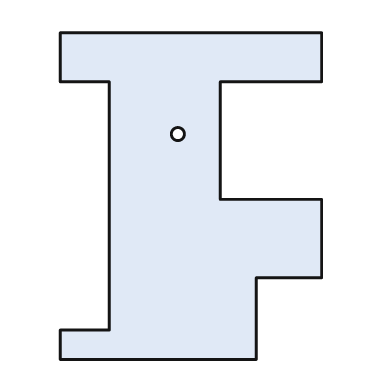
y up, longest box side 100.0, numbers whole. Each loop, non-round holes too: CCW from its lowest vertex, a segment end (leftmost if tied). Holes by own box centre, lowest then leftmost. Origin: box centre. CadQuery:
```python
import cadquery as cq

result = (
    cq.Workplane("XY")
    .moveTo(-40.0, -50.0)
    .lineTo(20.0, -50.0)
    .lineTo(20.0, -25.0)
    .lineTo(40.0, -25.0)
    .lineTo(40.0, -1.0)
    .lineTo(9.0, -1.0)
    .lineTo(9.0, 35.0)
    .lineTo(40.0, 35.0)
    .lineTo(40.0, 50.0)
    .lineTo(-40.0, 50.0)
    .lineTo(-40.0, 35.0)
    .lineTo(-25.0, 35.0)
    .lineTo(-25.0, -41.0)
    .lineTo(-40.0, -41.0)
    .close()
    .moveTo(-4.0, 19.0)
    .circle(2.0)
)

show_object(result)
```